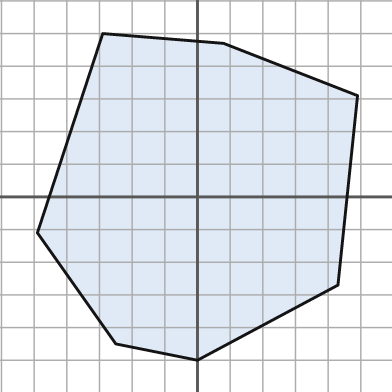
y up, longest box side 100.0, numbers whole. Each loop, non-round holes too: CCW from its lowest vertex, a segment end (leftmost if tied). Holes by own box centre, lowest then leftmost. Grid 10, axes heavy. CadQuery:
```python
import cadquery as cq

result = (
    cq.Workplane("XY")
    .moveTo(0.0, -50.0)
    .lineTo(43.0, -27.0)
    .lineTo(49.0, 31.0)
    .lineTo(8.0, 47.0)
    .lineTo(-29.0, 50.0)
    .lineTo(-49.0, -11.0)
    .lineTo(-25.0, -45.0)
    .close()
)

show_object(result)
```